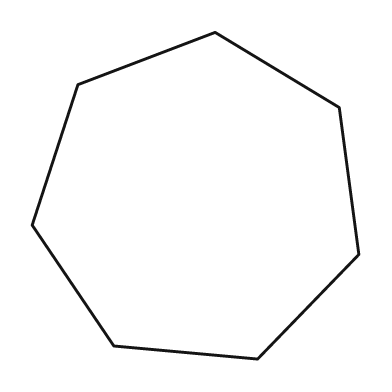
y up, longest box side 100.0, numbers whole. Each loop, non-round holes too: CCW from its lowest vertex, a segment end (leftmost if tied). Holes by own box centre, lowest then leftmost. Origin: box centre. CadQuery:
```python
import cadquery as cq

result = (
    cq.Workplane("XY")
    .moveTo(19.0, -50.0)
    .lineTo(50.0, -18.0)
    .lineTo(44.0, 27.0)
    .lineTo(6.0, 50.0)
    .lineTo(-36.0, 34.0)
    .lineTo(-50.0, -9.0)
    .lineTo(-25.0, -46.0)
    .close()
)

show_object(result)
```